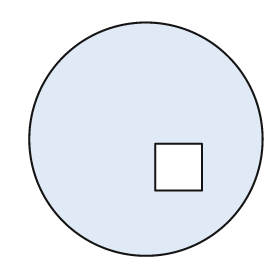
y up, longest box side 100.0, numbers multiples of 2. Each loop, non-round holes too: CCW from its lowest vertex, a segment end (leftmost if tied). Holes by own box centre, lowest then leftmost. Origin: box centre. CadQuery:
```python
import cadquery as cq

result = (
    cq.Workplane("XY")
    .moveTo(0.0, 0.0)
    .circle(50.0)
    .moveTo(4.0, -22.0)
    .lineTo(24.0, -22.0)
    .lineTo(24.0, -2.0)
    .lineTo(4.0, -2.0)
    .close()
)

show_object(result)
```